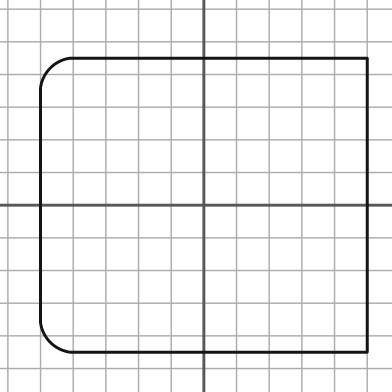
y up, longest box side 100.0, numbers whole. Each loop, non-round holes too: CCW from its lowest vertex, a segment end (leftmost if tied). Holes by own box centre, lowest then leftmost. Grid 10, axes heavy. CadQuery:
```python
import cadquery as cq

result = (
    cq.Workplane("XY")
    .moveTo(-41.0, -45.0)
    .lineTo(50.0, -45.0)
    .lineTo(50.0, 45.0)
    .lineTo(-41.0, 45.0)
    .threePointArc((-47.0, 42.0), (-50.0, 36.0))
    .lineTo(-50.0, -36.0)
    .threePointArc((-47.0, -42.0), (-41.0, -45.0))
    .close()
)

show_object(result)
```